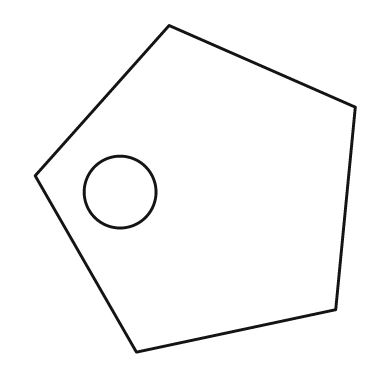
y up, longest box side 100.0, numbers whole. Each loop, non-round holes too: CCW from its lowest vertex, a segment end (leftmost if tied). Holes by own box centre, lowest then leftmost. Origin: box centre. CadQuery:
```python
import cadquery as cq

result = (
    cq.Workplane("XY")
    .moveTo(-18.0, -50.0)
    .lineTo(43.0, -37.0)
    .lineTo(49.0, 25.0)
    .lineTo(-8.0, 50.0)
    .lineTo(-49.0, 4.0)
    .close()
    .moveTo(-23.0, -1.0)
    .circle(11.0)
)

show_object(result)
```